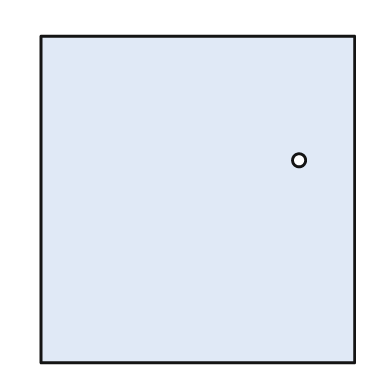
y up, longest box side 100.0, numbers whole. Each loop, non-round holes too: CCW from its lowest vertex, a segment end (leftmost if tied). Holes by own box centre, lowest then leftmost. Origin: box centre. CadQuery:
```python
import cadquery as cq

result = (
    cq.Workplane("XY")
    .moveTo(-48.0, -50.0)
    .lineTo(48.0, -50.0)
    .lineTo(48.0, 50.0)
    .lineTo(-48.0, 50.0)
    .close()
    .moveTo(31.0, 12.0)
    .circle(2.0)
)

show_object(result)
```